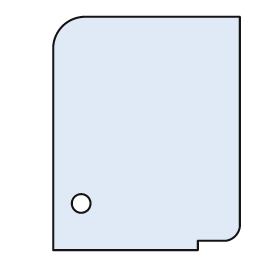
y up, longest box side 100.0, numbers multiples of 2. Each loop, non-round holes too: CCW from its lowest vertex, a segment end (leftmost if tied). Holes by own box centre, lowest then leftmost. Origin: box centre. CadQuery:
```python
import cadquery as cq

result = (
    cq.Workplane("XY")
    .moveTo(-40.0, -50.0)
    .lineTo(22.0, -50.0)
    .lineTo(22.0, -46.0)
    .lineTo(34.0, -46.0)
    .threePointArc((38.0, -44.0), (40.0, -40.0))
    .lineTo(40.0, 50.0)
    .lineTo(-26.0, 50.0)
    .threePointArc((-36.0, 46.0), (-40.0, 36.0))
    .close()
    .moveTo(-28.0, -30.0)
    .circle(4.0)
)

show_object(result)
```